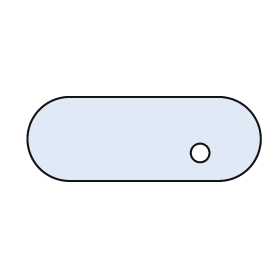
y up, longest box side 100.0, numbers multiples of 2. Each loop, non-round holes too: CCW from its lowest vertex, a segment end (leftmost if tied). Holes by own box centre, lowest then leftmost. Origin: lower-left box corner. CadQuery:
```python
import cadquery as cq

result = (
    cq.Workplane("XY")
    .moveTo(18.0, 0.0)
    .lineTo(82.0, 0.0)
    .threePointArc((100.0, 18.0), (82.0, 36.0))
    .lineTo(18.0, 36.0)
    .threePointArc((0.0, 18.0), (18.0, 0.0))
    .close()
    .moveTo(74.0, 12.0)
    .circle(4.0)
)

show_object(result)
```